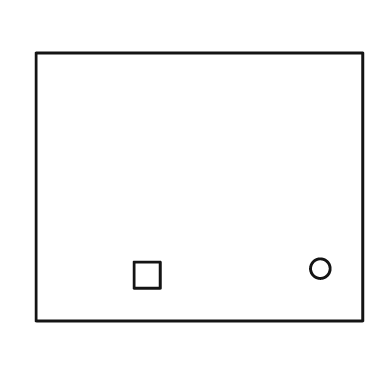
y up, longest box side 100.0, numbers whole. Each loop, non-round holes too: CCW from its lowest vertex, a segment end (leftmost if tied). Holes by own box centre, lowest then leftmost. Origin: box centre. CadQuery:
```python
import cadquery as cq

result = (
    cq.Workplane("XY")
    .moveTo(-50.0, -41.0)
    .lineTo(50.0, -41.0)
    .lineTo(50.0, 41.0)
    .lineTo(-50.0, 41.0)
    .close()
    .moveTo(-20.0, -31.0)
    .lineTo(-12.0, -31.0)
    .lineTo(-12.0, -23.0)
    .lineTo(-20.0, -23.0)
    .close()
    .moveTo(37.0, -25.0)
    .circle(3.0)
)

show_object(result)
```